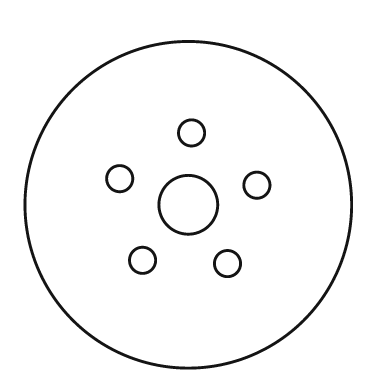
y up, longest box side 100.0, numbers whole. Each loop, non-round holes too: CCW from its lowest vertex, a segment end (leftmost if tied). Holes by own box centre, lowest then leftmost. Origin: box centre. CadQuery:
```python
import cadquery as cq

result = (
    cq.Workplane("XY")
    .moveTo(0.0, 0.0)
    .circle(50.0)
    .moveTo(12.0, -18.0)
    .circle(4.0)
    .moveTo(-14.0, -17.0)
    .circle(4.0)
    .moveTo(0.0, 0.0)
    .circle(9.0)
    .moveTo(21.0, 6.0)
    .circle(4.0)
    .moveTo(-21.0, 8.0)
    .circle(4.0)
    .moveTo(1.0, 22.0)
    .circle(4.0)
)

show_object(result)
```